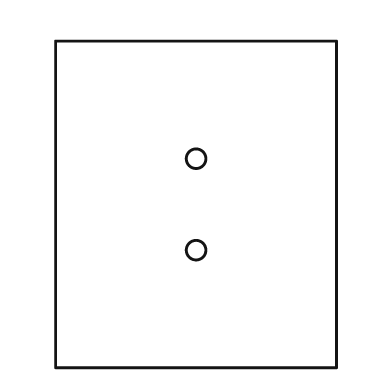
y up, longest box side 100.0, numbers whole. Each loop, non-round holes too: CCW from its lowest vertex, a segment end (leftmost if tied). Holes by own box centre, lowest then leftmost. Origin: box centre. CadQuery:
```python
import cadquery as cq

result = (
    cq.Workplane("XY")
    .moveTo(-43.0, -50.0)
    .lineTo(43.0, -50.0)
    .lineTo(43.0, 50.0)
    .lineTo(-43.0, 50.0)
    .close()
    .moveTo(0.0, -14.0)
    .circle(3.0)
    .moveTo(0.0, 14.0)
    .circle(3.0)
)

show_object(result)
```